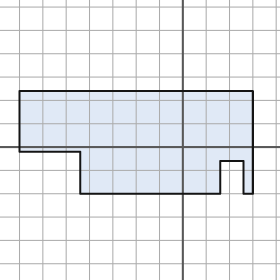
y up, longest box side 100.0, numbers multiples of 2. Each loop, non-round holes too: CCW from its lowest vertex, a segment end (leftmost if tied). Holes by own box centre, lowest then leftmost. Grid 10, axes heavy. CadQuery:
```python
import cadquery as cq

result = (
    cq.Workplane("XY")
    .moveTo(-44.0, -20.0)
    .lineTo(16.0, -20.0)
    .lineTo(16.0, -6.0)
    .lineTo(26.0, -6.0)
    .lineTo(26.0, -20.0)
    .lineTo(30.0, -20.0)
    .lineTo(30.0, 24.0)
    .lineTo(-70.0, 24.0)
    .lineTo(-70.0, -2.0)
    .lineTo(-44.0, -2.0)
    .close()
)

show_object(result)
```